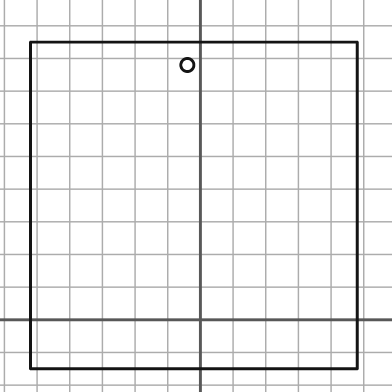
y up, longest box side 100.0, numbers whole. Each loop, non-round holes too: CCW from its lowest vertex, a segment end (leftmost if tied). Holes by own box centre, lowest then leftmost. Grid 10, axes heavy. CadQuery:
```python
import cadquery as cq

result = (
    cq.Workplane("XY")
    .moveTo(-52.0, -15.0)
    .lineTo(48.0, -15.0)
    .lineTo(48.0, 85.0)
    .lineTo(-52.0, 85.0)
    .close()
    .moveTo(-4.0, 78.0)
    .circle(2.0)
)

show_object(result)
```